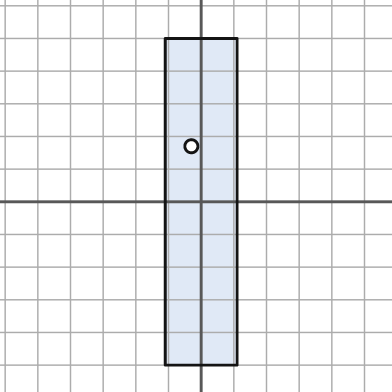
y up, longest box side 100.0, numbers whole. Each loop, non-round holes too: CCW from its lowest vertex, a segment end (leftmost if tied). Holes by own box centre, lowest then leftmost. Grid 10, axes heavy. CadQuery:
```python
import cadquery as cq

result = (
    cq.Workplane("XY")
    .moveTo(-11.0, -50.0)
    .lineTo(11.0, -50.0)
    .lineTo(11.0, 50.0)
    .lineTo(-11.0, 50.0)
    .close()
    .moveTo(-3.0, 17.0)
    .circle(2.0)
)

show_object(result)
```